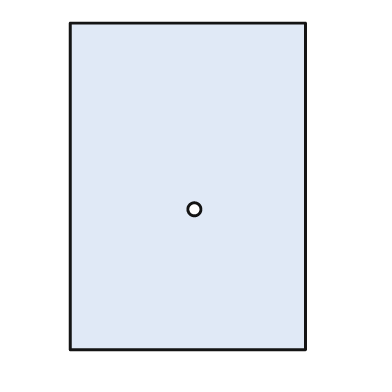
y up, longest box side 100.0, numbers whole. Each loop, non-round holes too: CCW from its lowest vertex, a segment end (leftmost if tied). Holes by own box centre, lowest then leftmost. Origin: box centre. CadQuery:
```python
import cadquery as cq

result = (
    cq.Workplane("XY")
    .moveTo(-36.0, -50.0)
    .lineTo(36.0, -50.0)
    .lineTo(36.0, 50.0)
    .lineTo(-36.0, 50.0)
    .close()
    .moveTo(2.0, -7.0)
    .circle(2.0)
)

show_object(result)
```